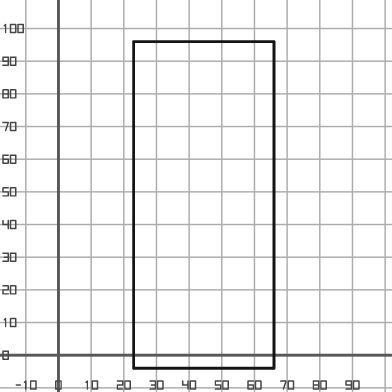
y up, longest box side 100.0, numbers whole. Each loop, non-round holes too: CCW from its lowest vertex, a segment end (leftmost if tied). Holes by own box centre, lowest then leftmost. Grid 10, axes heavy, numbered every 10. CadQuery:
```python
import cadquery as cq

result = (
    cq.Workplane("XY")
    .moveTo(23.0, -4.0)
    .lineTo(66.0, -4.0)
    .lineTo(66.0, 96.0)
    .lineTo(23.0, 96.0)
    .close()
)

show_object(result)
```